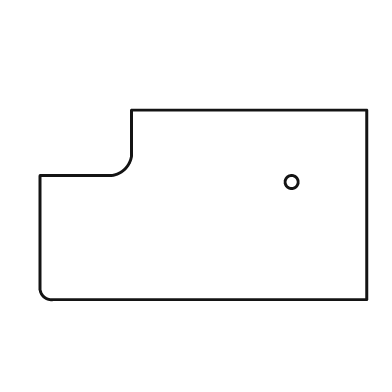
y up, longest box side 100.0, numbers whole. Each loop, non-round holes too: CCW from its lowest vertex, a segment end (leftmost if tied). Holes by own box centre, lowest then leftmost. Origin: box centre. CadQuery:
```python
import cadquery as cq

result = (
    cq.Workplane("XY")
    .moveTo(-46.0, -29.0)
    .lineTo(50.0, -29.0)
    .lineTo(50.0, 29.0)
    .lineTo(-22.0, 29.0)
    .lineTo(-22.0, 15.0)
    .threePointArc((-24.0, 11.0), (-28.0, 9.0))
    .lineTo(-50.0, 9.0)
    .lineTo(-50.0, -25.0)
    .threePointArc((-49.0, -28.0), (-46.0, -29.0))
    .close()
    .moveTo(27.0, 7.0)
    .circle(2.0)
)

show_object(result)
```